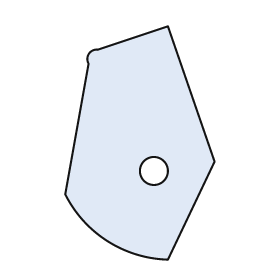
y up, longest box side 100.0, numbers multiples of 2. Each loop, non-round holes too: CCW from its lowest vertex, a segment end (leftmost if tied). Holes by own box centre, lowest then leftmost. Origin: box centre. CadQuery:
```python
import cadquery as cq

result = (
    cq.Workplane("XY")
    .moveTo(12.0, -50.0)
    .lineTo(32.0, -8.0)
    .lineTo(12.0, 50.0)
    .lineTo(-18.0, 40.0)
    .threePointArc((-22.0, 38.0), (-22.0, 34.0))
    .lineTo(-32.0, -22.0)
    .threePointArc((-14.0, -42.0), (12.0, -50.0))
    .close()
    .moveTo(6.0, -12.0)
    .circle(6.0)
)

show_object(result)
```